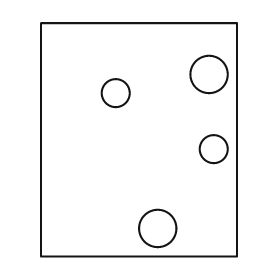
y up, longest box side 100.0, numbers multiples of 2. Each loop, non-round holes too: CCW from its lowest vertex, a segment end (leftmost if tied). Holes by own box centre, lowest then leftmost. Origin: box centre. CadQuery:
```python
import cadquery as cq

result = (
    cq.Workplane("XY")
    .moveTo(-42.0, -50.0)
    .lineTo(42.0, -50.0)
    .lineTo(42.0, 50.0)
    .lineTo(-42.0, 50.0)
    .close()
    .moveTo(8.0, -38.0)
    .circle(8.0)
    .moveTo(32.0, -4.0)
    .circle(6.0)
    .moveTo(-10.0, 20.0)
    .circle(6.0)
    .moveTo(30.0, 28.0)
    .circle(8.0)
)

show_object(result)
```